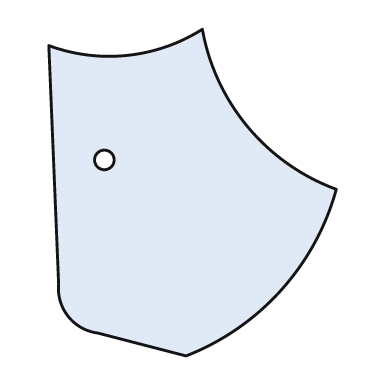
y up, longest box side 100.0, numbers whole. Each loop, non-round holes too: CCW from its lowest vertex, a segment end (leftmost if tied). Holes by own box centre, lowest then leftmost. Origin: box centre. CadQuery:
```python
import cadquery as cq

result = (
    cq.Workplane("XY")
    .moveTo(-2.0, -50.0)
    .threePointArc((27.0, -30.0), (44.0, 1.0))
    .threePointArc((17.0, 20.0), (3.0, 50.0))
    .threePointArc((-20.0, 42.0), (-44.0, 45.0))
    .lineTo(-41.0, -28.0)
    .threePointArc((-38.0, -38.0), (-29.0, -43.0))
    .close()
    .moveTo(-27.0, 10.0)
    .circle(3.0)
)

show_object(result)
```